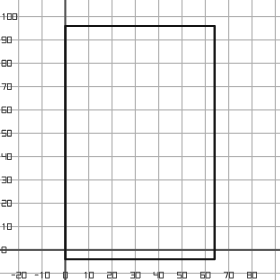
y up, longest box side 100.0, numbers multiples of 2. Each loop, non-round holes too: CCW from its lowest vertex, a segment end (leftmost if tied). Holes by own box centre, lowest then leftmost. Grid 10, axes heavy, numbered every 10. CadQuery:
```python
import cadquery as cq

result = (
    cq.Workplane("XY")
    .moveTo(0.0, -4.0)
    .lineTo(64.0, -4.0)
    .lineTo(64.0, 96.0)
    .lineTo(0.0, 96.0)
    .close()
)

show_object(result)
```